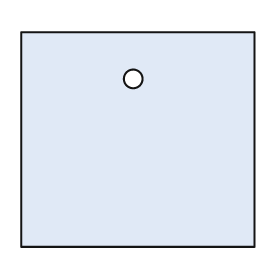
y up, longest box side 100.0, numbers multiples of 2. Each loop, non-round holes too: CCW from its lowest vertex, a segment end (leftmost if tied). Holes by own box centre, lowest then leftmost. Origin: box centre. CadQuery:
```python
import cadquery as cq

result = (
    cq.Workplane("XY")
    .moveTo(-50.0, -46.0)
    .lineTo(50.0, -46.0)
    .lineTo(50.0, 46.0)
    .lineTo(-50.0, 46.0)
    .close()
    .moveTo(-2.0, 26.0)
    .circle(4.0)
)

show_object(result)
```